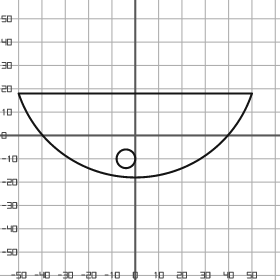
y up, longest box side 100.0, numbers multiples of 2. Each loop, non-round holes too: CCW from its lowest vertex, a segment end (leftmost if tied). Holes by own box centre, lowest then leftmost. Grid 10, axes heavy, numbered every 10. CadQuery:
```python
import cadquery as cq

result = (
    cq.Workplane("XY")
    .moveTo(-50.0, 18.0)
    .threePointArc((0.0, -18.0), (50.0, 18.0))
    .close()
    .moveTo(-4.0, -10.0)
    .circle(4.0)
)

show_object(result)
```